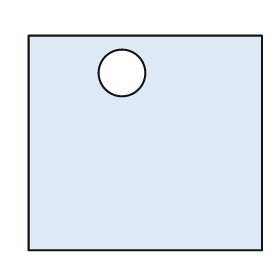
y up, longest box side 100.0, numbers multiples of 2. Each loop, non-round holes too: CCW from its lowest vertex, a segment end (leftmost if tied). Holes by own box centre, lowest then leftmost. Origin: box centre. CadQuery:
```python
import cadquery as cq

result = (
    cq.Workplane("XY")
    .moveTo(-50.0, -46.0)
    .lineTo(50.0, -46.0)
    .lineTo(50.0, 46.0)
    .lineTo(-50.0, 46.0)
    .close()
    .moveTo(-10.0, 30.0)
    .circle(10.0)
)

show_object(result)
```